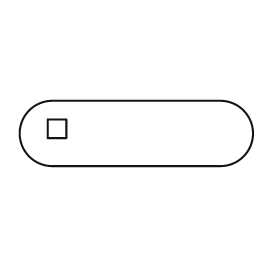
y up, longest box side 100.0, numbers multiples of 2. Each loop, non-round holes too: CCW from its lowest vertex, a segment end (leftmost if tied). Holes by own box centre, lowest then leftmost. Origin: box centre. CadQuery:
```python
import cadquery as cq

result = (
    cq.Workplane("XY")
    .moveTo(-36.0, -14.0)
    .lineTo(36.0, -14.0)
    .threePointArc((50.0, 0.0), (36.0, 14.0))
    .lineTo(-36.0, 14.0)
    .threePointArc((-50.0, 0.0), (-36.0, -14.0))
    .close()
    .moveTo(-38.0, -2.0)
    .lineTo(-30.0, -2.0)
    .lineTo(-30.0, 6.0)
    .lineTo(-38.0, 6.0)
    .close()
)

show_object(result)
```